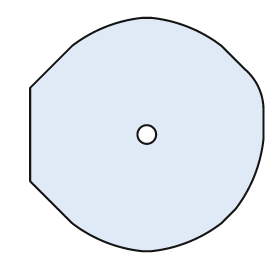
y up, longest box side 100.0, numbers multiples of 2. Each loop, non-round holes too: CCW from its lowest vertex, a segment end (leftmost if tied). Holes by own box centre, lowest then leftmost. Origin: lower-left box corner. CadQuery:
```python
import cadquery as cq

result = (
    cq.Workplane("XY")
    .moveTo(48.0, 0.0)
    .lineTo(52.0, 0.0)
    .threePointArc((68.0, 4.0), (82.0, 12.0))
    .lineTo(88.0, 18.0)
    .threePointArc((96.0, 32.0), (100.0, 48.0))
    .lineTo(100.0, 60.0)
    .threePointArc((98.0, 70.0), (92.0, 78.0))
    .lineTo(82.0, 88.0)
    .threePointArc((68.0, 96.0), (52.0, 100.0))
    .lineTo(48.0, 100.0)
    .threePointArc((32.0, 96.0), (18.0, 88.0))
    .lineTo(0.0, 70.0)
    .lineTo(0.0, 30.0)
    .lineTo(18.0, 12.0)
    .threePointArc((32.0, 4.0), (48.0, 0.0))
    .close()
    .moveTo(50.0, 50.0)
    .circle(4.0)
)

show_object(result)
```